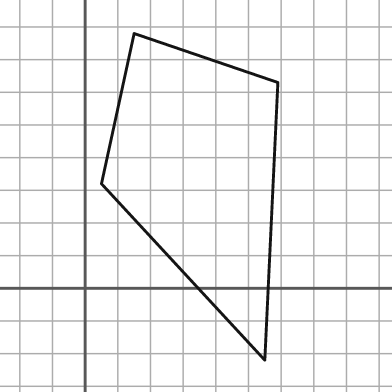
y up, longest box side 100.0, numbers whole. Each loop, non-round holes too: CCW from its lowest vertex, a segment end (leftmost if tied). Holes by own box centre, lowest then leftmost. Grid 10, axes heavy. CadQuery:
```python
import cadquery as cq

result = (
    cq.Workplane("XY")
    .moveTo(55.0, -22.0)
    .lineTo(59.0, 63.0)
    .lineTo(15.0, 78.0)
    .lineTo(5.0, 32.0)
    .close()
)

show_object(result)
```